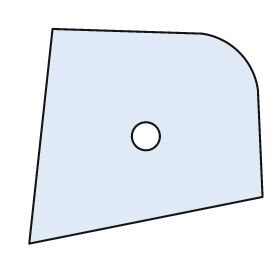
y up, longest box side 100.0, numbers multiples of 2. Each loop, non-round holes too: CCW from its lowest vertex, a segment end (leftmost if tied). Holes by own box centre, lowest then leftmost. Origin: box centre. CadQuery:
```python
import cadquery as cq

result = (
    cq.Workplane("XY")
    .moveTo(-50.0, -46.0)
    .lineTo(50.0, -26.0)
    .lineTo(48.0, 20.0)
    .threePointArc((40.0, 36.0), (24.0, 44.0))
    .lineTo(-40.0, 46.0)
    .close()
    .moveTo(0.0, 0.0)
    .circle(6.0)
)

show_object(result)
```